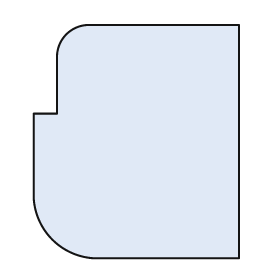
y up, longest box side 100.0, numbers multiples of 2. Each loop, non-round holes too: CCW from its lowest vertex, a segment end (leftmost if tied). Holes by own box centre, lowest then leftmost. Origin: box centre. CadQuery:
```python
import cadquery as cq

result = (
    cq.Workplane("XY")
    .moveTo(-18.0, -50.0)
    .lineTo(44.0, -50.0)
    .lineTo(44.0, 50.0)
    .lineTo(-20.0, 50.0)
    .threePointArc((-30.0, 46.0), (-34.0, 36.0))
    .lineTo(-34.0, 12.0)
    .lineTo(-44.0, 12.0)
    .lineTo(-44.0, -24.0)
    .threePointArc((-36.0, -42.0), (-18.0, -50.0))
    .close()
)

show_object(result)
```